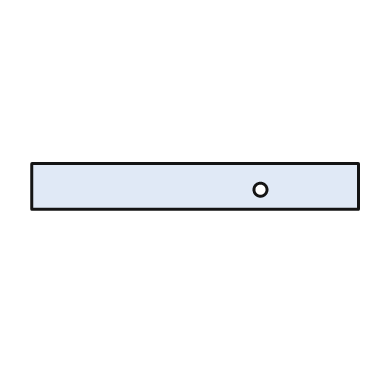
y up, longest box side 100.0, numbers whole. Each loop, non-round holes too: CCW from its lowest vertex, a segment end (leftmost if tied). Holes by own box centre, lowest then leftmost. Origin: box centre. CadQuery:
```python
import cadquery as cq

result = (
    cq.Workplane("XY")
    .moveTo(-50.0, -7.0)
    .lineTo(50.0, -7.0)
    .lineTo(50.0, 7.0)
    .lineTo(-50.0, 7.0)
    .close()
    .moveTo(20.0, -1.0)
    .circle(2.0)
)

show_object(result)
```